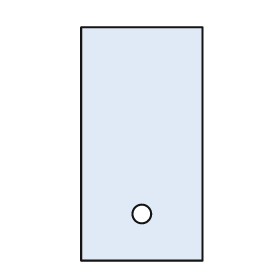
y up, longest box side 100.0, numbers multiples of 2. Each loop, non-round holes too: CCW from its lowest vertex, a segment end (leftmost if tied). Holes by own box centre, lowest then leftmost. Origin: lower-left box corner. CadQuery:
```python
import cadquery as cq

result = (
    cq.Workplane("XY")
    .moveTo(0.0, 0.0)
    .lineTo(52.0, 0.0)
    .lineTo(52.0, 100.0)
    .lineTo(0.0, 100.0)
    .close()
    .moveTo(26.0, 20.0)
    .circle(4.0)
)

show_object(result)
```